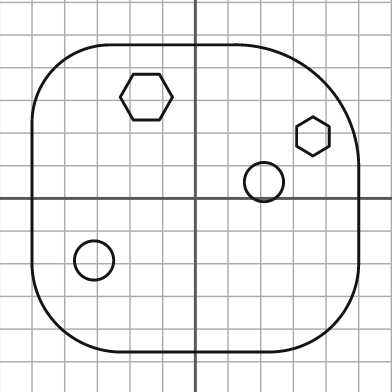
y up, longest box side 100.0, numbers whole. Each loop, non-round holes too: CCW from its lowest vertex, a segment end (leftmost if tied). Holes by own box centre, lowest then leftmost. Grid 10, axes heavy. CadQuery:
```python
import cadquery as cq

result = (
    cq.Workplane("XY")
    .moveTo(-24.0, -47.0)
    .lineTo(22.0, -47.0)
    .threePointArc((42.0, -39.0), (50.0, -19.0))
    .lineTo(50.0, 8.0)
    .threePointArc((39.0, 36.0), (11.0, 47.0))
    .lineTo(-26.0, 47.0)
    .threePointArc((-43.0, 40.0), (-50.0, 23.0))
    .lineTo(-50.0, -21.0)
    .threePointArc((-42.0, -39.0), (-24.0, -47.0))
    .close()
    .moveTo(-31.0, -19.0)
    .circle(6.0)
    .moveTo(21.0, 5.0)
    .circle(6.0)
    .moveTo(36.0, 13.0)
    .lineTo(41.0, 16.0)
    .lineTo(41.0, 22.0)
    .lineTo(36.0, 25.0)
    .lineTo(31.0, 22.0)
    .lineTo(31.0, 16.0)
    .close()
    .moveTo(-19.0, 24.0)
    .lineTo(-11.0, 24.0)
    .lineTo(-7.0, 31.0)
    .lineTo(-11.0, 38.0)
    .lineTo(-19.0, 38.0)
    .lineTo(-23.0, 31.0)
    .close()
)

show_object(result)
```